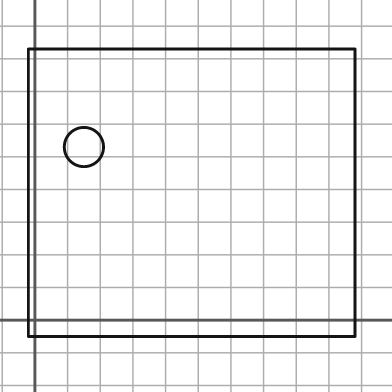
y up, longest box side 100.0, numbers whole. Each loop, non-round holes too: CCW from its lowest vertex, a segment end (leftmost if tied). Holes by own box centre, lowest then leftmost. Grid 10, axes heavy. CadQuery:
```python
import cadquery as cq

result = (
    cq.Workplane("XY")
    .moveTo(-2.0, -5.0)
    .lineTo(98.0, -5.0)
    .lineTo(98.0, 83.0)
    .lineTo(-2.0, 83.0)
    .close()
    .moveTo(15.0, 53.0)
    .circle(6.0)
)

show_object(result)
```